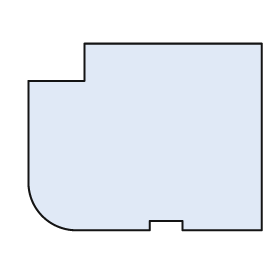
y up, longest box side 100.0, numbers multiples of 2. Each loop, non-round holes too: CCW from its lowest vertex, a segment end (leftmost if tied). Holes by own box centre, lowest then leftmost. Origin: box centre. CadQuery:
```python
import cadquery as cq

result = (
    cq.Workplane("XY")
    .moveTo(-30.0, -40.0)
    .lineTo(2.0, -40.0)
    .lineTo(2.0, -36.0)
    .lineTo(16.0, -36.0)
    .lineTo(16.0, -40.0)
    .lineTo(50.0, -40.0)
    .lineTo(50.0, 40.0)
    .lineTo(-26.0, 40.0)
    .lineTo(-26.0, 24.0)
    .lineTo(-50.0, 24.0)
    .lineTo(-50.0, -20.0)
    .threePointArc((-44.0, -34.0), (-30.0, -40.0))
    .close()
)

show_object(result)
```